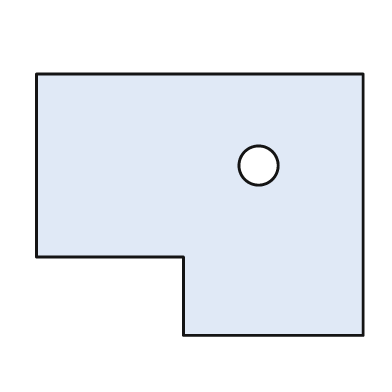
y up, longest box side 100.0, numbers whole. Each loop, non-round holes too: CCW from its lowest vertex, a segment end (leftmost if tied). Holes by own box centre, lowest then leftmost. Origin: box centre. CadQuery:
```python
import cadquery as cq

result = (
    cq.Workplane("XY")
    .moveTo(-5.0, -40.0)
    .lineTo(50.0, -40.0)
    .lineTo(50.0, 40.0)
    .lineTo(-50.0, 40.0)
    .lineTo(-50.0, -16.0)
    .lineTo(-5.0, -16.0)
    .close()
    .moveTo(18.0, 12.0)
    .circle(6.0)
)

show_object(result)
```